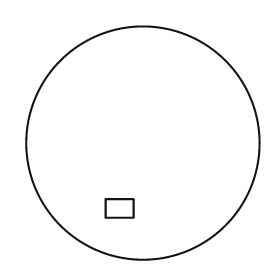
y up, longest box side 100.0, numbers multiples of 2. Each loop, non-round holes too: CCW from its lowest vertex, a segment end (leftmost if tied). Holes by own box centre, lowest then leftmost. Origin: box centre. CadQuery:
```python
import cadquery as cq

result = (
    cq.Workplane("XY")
    .moveTo(0.0, 0.0)
    .circle(50.0)
    .moveTo(-16.0, -32.0)
    .lineTo(-4.0, -32.0)
    .lineTo(-4.0, -24.0)
    .lineTo(-16.0, -24.0)
    .close()
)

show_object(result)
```